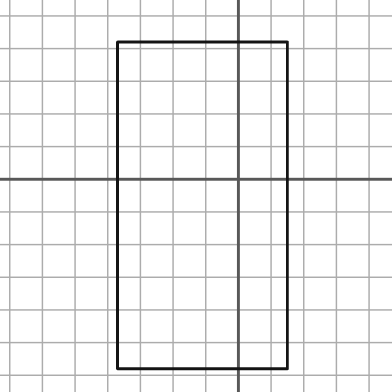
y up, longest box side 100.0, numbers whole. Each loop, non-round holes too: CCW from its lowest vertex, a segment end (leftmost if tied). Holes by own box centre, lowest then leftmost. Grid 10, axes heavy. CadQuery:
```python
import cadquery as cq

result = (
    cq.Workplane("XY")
    .moveTo(-37.0, -58.0)
    .lineTo(15.0, -58.0)
    .lineTo(15.0, 42.0)
    .lineTo(-37.0, 42.0)
    .close()
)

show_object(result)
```